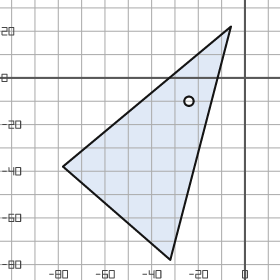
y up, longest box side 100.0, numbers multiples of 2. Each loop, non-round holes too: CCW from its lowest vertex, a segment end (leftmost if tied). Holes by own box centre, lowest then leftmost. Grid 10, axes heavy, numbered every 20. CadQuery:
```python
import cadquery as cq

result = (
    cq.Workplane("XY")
    .moveTo(-32.0, -78.0)
    .lineTo(-6.0, 22.0)
    .lineTo(-78.0, -38.0)
    .close()
    .moveTo(-24.0, -10.0)
    .circle(2.0)
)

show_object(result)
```